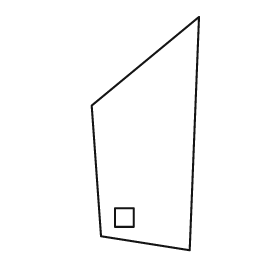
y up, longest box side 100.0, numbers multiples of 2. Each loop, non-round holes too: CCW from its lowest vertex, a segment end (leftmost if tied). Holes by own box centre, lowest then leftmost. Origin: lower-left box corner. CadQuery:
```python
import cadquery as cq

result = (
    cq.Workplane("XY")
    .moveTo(42.0, 0.0)
    .lineTo(46.0, 100.0)
    .lineTo(0.0, 62.0)
    .lineTo(4.0, 6.0)
    .close()
    .moveTo(10.0, 10.0)
    .lineTo(18.0, 10.0)
    .lineTo(18.0, 18.0)
    .lineTo(10.0, 18.0)
    .close()
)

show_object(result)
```